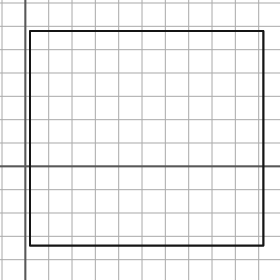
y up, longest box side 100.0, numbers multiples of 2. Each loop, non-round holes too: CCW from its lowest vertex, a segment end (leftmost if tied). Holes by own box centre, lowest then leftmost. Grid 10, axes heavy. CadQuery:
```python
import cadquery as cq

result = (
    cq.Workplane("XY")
    .moveTo(2.0, -34.0)
    .lineTo(102.0, -34.0)
    .lineTo(102.0, 58.0)
    .lineTo(2.0, 58.0)
    .close()
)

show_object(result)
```